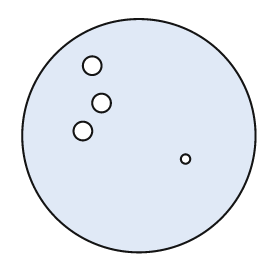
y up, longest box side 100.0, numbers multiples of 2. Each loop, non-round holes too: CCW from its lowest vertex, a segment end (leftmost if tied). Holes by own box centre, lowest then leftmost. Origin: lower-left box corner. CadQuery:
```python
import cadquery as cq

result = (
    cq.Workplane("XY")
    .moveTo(50.0, 50.0)
    .circle(50.0)
    .moveTo(70.0, 40.0)
    .circle(2.0)
    .moveTo(26.0, 52.0)
    .circle(4.0)
    .moveTo(34.0, 64.0)
    .circle(4.0)
    .moveTo(30.0, 80.0)
    .circle(4.0)
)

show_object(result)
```